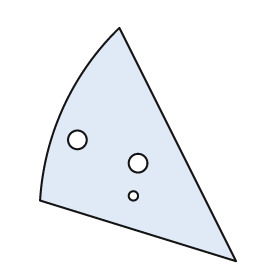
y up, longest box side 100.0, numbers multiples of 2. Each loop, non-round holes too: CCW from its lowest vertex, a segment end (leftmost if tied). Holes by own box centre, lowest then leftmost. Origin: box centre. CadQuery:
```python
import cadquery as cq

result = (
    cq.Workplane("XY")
    .moveTo(42.0, -50.0)
    .lineTo(-8.0, 50.0)
    .threePointArc((-32.0, 16.0), (-42.0, -24.0))
    .close()
    .moveTo(-2.0, -22.0)
    .circle(2.0)
    .moveTo(0.0, -8.0)
    .circle(4.0)
    .moveTo(-26.0, 2.0)
    .circle(4.0)
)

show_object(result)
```